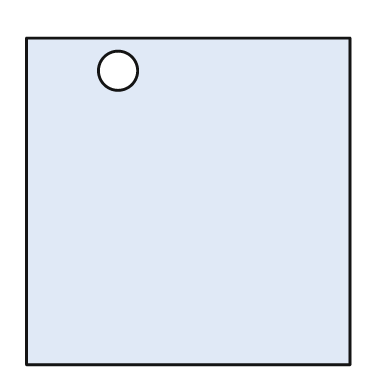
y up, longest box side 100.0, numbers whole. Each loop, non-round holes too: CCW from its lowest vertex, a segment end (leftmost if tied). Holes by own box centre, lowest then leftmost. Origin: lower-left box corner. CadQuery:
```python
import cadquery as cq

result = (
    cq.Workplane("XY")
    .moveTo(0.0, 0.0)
    .lineTo(99.0, 0.0)
    .lineTo(99.0, 100.0)
    .lineTo(0.0, 100.0)
    .close()
    .moveTo(28.0, 90.0)
    .circle(6.0)
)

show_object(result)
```